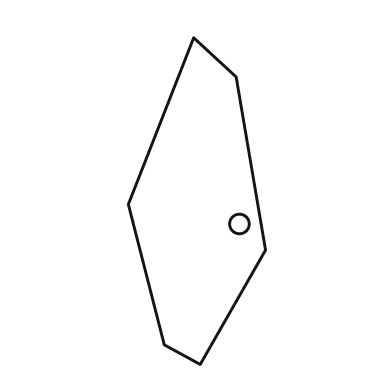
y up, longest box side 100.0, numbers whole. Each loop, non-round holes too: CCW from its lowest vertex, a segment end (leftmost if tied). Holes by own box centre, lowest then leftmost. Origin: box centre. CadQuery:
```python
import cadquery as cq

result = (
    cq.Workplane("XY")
    .moveTo(1.0, -50.0)
    .lineTo(21.0, -15.0)
    .lineTo(12.0, 38.0)
    .lineTo(-1.0, 50.0)
    .lineTo(-21.0, -1.0)
    .lineTo(-10.0, -44.0)
    .close()
    .moveTo(13.0, -7.0)
    .circle(3.0)
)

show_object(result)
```